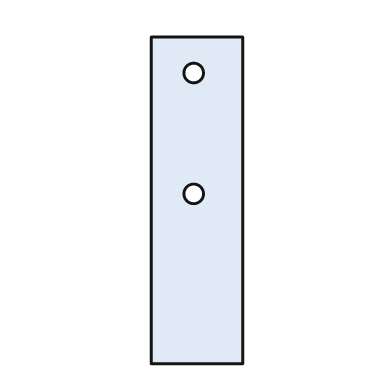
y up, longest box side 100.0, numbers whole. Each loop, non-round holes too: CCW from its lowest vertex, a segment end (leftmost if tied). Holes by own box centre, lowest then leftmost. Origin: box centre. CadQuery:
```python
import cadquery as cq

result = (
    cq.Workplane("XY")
    .moveTo(-14.0, -50.0)
    .lineTo(14.0, -50.0)
    .lineTo(14.0, 50.0)
    .lineTo(-14.0, 50.0)
    .close()
    .moveTo(-1.0, 2.0)
    .circle(3.0)
    .moveTo(-1.0, 39.0)
    .circle(3.0)
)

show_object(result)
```